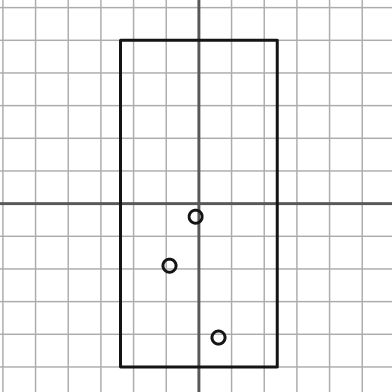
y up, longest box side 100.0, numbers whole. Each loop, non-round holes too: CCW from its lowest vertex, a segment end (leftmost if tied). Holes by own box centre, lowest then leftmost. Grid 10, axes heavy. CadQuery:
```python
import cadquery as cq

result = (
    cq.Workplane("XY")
    .moveTo(-24.0, -50.0)
    .lineTo(24.0, -50.0)
    .lineTo(24.0, 50.0)
    .lineTo(-24.0, 50.0)
    .close()
    .moveTo(6.0, -41.0)
    .circle(2.0)
    .moveTo(-9.0, -19.0)
    .circle(2.0)
    .moveTo(-1.0, -4.0)
    .circle(2.0)
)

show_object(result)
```